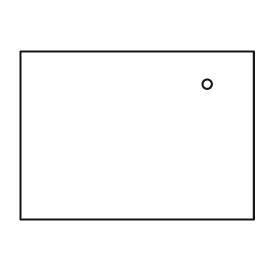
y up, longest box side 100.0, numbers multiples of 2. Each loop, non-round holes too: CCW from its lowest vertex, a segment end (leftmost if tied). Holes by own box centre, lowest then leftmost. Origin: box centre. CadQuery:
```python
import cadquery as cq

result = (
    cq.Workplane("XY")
    .moveTo(-50.0, -36.0)
    .lineTo(50.0, -36.0)
    .lineTo(50.0, 36.0)
    .lineTo(-50.0, 36.0)
    .close()
    .moveTo(30.0, 22.0)
    .circle(2.0)
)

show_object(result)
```